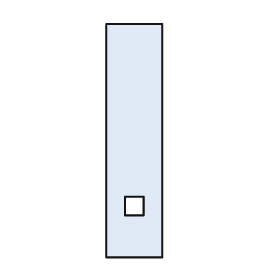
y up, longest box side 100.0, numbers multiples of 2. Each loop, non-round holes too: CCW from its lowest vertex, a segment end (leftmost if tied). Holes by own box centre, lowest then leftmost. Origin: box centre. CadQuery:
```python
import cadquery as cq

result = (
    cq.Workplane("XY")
    .moveTo(-12.0, -50.0)
    .lineTo(12.0, -50.0)
    .lineTo(12.0, 50.0)
    .lineTo(-12.0, 50.0)
    .close()
    .moveTo(-4.0, -32.0)
    .lineTo(4.0, -32.0)
    .lineTo(4.0, -24.0)
    .lineTo(-4.0, -24.0)
    .close()
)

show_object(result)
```